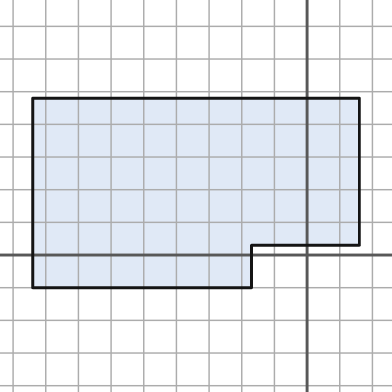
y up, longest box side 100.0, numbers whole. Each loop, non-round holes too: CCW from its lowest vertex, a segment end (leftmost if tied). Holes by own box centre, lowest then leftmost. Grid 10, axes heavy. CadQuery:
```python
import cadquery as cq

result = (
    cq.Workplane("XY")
    .moveTo(-84.0, -10.0)
    .lineTo(-17.0, -10.0)
    .lineTo(-17.0, 3.0)
    .lineTo(16.0, 3.0)
    .lineTo(16.0, 48.0)
    .lineTo(-84.0, 48.0)
    .close()
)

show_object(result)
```